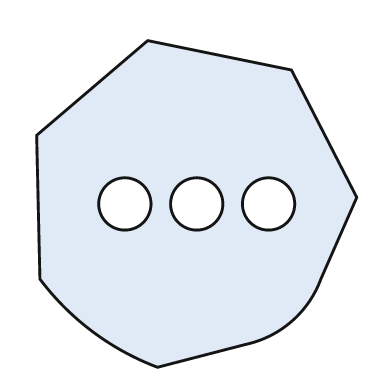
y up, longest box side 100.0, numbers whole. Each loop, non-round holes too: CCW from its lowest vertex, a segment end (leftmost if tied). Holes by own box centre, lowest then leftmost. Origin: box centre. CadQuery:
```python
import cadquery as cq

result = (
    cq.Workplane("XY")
    .moveTo(-12.0, -50.0)
    .lineTo(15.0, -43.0)
    .threePointArc((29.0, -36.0), (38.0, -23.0))
    .lineTo(49.0, 2.0)
    .lineTo(29.0, 41.0)
    .lineTo(-15.0, 50.0)
    .lineTo(-49.0, 21.0)
    .lineTo(-48.0, -23.0)
    .threePointArc((-32.0, -39.0), (-12.0, -50.0))
    .close()
    .moveTo(-22.0, 0.0)
    .circle(8.0)
    .moveTo(0.0, 0.0)
    .circle(8.0)
    .moveTo(22.0, 0.0)
    .circle(8.0)
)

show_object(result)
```